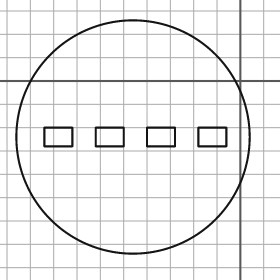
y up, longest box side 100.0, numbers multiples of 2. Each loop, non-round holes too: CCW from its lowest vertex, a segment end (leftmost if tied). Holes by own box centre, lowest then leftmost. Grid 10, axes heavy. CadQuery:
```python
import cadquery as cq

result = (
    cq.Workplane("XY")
    .moveTo(-46.0, -24.0)
    .circle(50.0)
    .moveTo(-84.0, -28.0)
    .lineTo(-72.0, -28.0)
    .lineTo(-72.0, -20.0)
    .lineTo(-84.0, -20.0)
    .close()
    .moveTo(-62.0, -28.0)
    .lineTo(-50.0, -28.0)
    .lineTo(-50.0, -20.0)
    .lineTo(-62.0, -20.0)
    .close()
    .moveTo(-40.0, -28.0)
    .lineTo(-28.0, -28.0)
    .lineTo(-28.0, -20.0)
    .lineTo(-40.0, -20.0)
    .close()
    .moveTo(-18.0, -28.0)
    .lineTo(-6.0, -28.0)
    .lineTo(-6.0, -20.0)
    .lineTo(-18.0, -20.0)
    .close()
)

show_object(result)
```